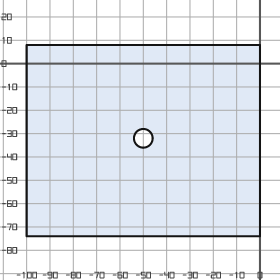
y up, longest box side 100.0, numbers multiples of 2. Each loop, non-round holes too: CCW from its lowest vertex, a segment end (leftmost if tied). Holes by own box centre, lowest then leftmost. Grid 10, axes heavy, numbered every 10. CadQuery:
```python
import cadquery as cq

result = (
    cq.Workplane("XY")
    .moveTo(-100.0, -74.0)
    .lineTo(0.0, -74.0)
    .lineTo(0.0, 8.0)
    .lineTo(-100.0, 8.0)
    .close()
    .moveTo(-50.0, -32.0)
    .circle(4.0)
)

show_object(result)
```